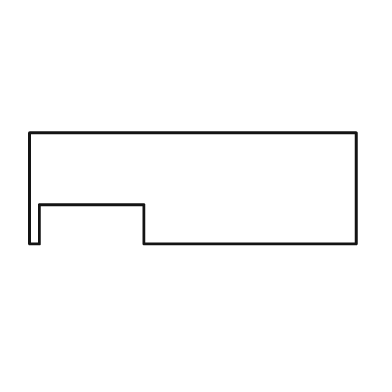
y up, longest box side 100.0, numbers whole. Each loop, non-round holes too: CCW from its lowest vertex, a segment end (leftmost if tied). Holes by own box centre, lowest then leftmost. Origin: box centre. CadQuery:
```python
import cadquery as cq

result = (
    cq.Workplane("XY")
    .moveTo(-50.0, -17.0)
    .lineTo(-47.0, -17.0)
    .lineTo(-47.0, -5.0)
    .lineTo(-15.0, -5.0)
    .lineTo(-15.0, -17.0)
    .lineTo(50.0, -17.0)
    .lineTo(50.0, 17.0)
    .lineTo(-50.0, 17.0)
    .close()
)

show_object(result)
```